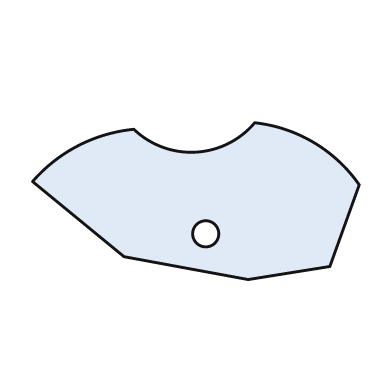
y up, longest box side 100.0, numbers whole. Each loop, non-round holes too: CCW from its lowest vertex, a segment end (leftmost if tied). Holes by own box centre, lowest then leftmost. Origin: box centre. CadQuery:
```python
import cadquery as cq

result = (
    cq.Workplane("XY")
    .moveTo(16.0, -24.0)
    .lineTo(41.0, -20.0)
    .lineTo(50.0, 5.0)
    .threePointArc((36.0, 18.0), (18.0, 24.0))
    .threePointArc((0.0, 15.0), (-19.0, 22.0))
    .threePointArc((-36.0, 17.0), (-50.0, 6.0))
    .lineTo(-22.0, -17.0)
    .close()
    .moveTo(3.0, -10.0)
    .circle(4.0)
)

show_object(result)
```